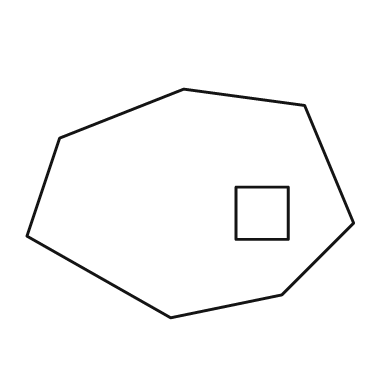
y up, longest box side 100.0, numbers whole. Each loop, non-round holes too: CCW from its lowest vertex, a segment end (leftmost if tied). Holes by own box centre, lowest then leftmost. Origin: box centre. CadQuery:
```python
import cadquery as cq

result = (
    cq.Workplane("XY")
    .moveTo(-6.0, -35.0)
    .lineTo(28.0, -28.0)
    .lineTo(50.0, -6.0)
    .lineTo(35.0, 30.0)
    .lineTo(-2.0, 35.0)
    .lineTo(-40.0, 20.0)
    .lineTo(-50.0, -10.0)
    .close()
    .moveTo(14.0, -11.0)
    .lineTo(30.0, -11.0)
    .lineTo(30.0, 5.0)
    .lineTo(14.0, 5.0)
    .close()
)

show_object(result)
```